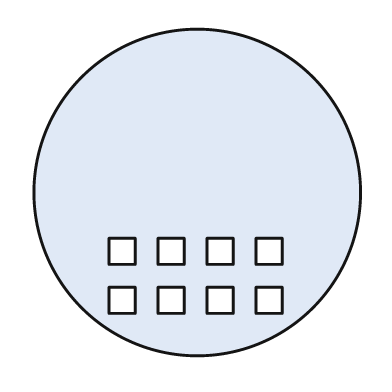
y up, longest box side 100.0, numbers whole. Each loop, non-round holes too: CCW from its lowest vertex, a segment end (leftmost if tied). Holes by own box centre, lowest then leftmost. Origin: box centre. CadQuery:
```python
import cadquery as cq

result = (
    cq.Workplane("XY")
    .moveTo(0.0, 0.0)
    .circle(50.0)
    .moveTo(-27.0, -37.0)
    .lineTo(-19.0, -37.0)
    .lineTo(-19.0, -29.0)
    .lineTo(-27.0, -29.0)
    .close()
    .moveTo(-12.0, -37.0)
    .lineTo(-4.0, -37.0)
    .lineTo(-4.0, -29.0)
    .lineTo(-12.0, -29.0)
    .close()
    .moveTo(3.0, -37.0)
    .lineTo(11.0, -37.0)
    .lineTo(11.0, -29.0)
    .lineTo(3.0, -29.0)
    .close()
    .moveTo(18.0, -37.0)
    .lineTo(26.0, -37.0)
    .lineTo(26.0, -29.0)
    .lineTo(18.0, -29.0)
    .close()
    .moveTo(-27.0, -22.0)
    .lineTo(-19.0, -22.0)
    .lineTo(-19.0, -14.0)
    .lineTo(-27.0, -14.0)
    .close()
    .moveTo(-12.0, -22.0)
    .lineTo(-4.0, -22.0)
    .lineTo(-4.0, -14.0)
    .lineTo(-12.0, -14.0)
    .close()
    .moveTo(3.0, -22.0)
    .lineTo(11.0, -22.0)
    .lineTo(11.0, -14.0)
    .lineTo(3.0, -14.0)
    .close()
    .moveTo(18.0, -22.0)
    .lineTo(26.0, -22.0)
    .lineTo(26.0, -14.0)
    .lineTo(18.0, -14.0)
    .close()
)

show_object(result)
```